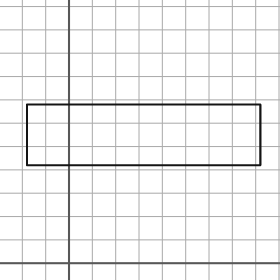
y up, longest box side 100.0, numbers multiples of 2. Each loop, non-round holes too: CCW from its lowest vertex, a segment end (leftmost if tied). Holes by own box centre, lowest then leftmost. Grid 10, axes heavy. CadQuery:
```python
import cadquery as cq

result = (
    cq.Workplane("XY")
    .moveTo(-18.0, 42.0)
    .lineTo(82.0, 42.0)
    .lineTo(82.0, 68.0)
    .lineTo(-18.0, 68.0)
    .close()
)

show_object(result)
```